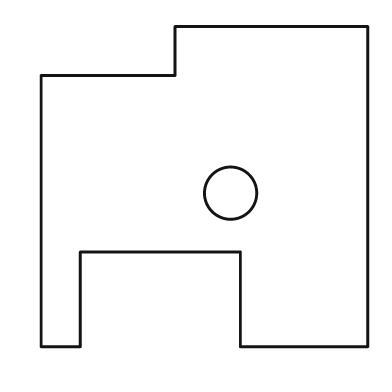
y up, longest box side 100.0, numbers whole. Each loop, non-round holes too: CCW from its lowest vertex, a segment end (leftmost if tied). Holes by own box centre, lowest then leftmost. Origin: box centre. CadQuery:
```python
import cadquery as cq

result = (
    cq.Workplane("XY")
    .moveTo(-50.0, -49.0)
    .lineTo(-38.0, -49.0)
    .lineTo(-38.0, -20.0)
    .lineTo(11.0, -20.0)
    .lineTo(11.0, -49.0)
    .lineTo(50.0, -49.0)
    .lineTo(50.0, 49.0)
    .lineTo(-9.0, 49.0)
    .lineTo(-9.0, 34.0)
    .lineTo(-50.0, 34.0)
    .close()
    .moveTo(8.0, -2.0)
    .circle(8.0)
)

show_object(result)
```